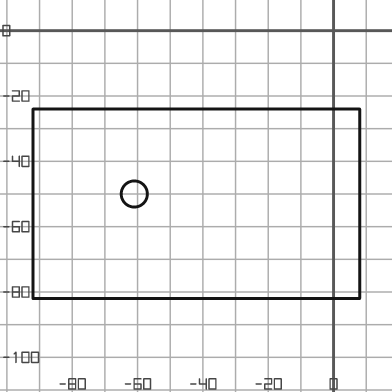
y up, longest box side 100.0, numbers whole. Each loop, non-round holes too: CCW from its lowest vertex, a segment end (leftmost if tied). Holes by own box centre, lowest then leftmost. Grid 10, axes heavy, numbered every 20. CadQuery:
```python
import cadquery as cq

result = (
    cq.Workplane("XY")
    .moveTo(-92.0, -82.0)
    .lineTo(8.0, -82.0)
    .lineTo(8.0, -24.0)
    .lineTo(-92.0, -24.0)
    .close()
    .moveTo(-61.0, -50.0)
    .circle(4.0)
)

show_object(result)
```